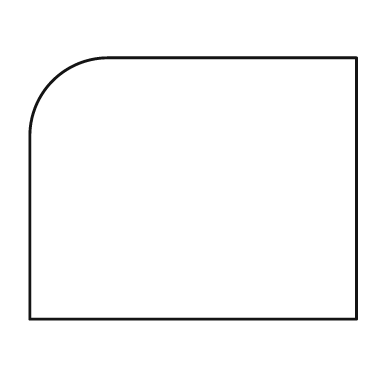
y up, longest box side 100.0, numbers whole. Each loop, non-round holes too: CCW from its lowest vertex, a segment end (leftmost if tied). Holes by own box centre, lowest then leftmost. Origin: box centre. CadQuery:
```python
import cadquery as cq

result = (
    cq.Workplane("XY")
    .moveTo(-50.0, -40.0)
    .lineTo(50.0, -40.0)
    .lineTo(50.0, 40.0)
    .lineTo(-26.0, 40.0)
    .threePointArc((-43.0, 33.0), (-50.0, 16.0))
    .close()
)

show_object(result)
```